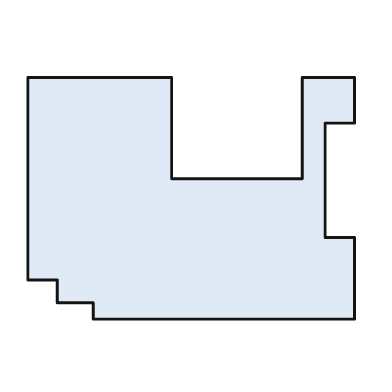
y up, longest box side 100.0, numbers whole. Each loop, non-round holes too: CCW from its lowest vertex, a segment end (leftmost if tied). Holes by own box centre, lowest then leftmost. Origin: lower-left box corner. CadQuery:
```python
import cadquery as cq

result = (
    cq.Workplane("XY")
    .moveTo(20.0, 0.0)
    .lineTo(100.0, 0.0)
    .lineTo(100.0, 25.0)
    .lineTo(91.0, 25.0)
    .lineTo(91.0, 60.0)
    .lineTo(100.0, 60.0)
    .lineTo(100.0, 74.0)
    .lineTo(84.0, 74.0)
    .lineTo(84.0, 43.0)
    .lineTo(44.0, 43.0)
    .lineTo(44.0, 74.0)
    .lineTo(0.0, 74.0)
    .lineTo(0.0, 12.0)
    .lineTo(9.0, 12.0)
    .lineTo(9.0, 5.0)
    .lineTo(20.0, 5.0)
    .close()
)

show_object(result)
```